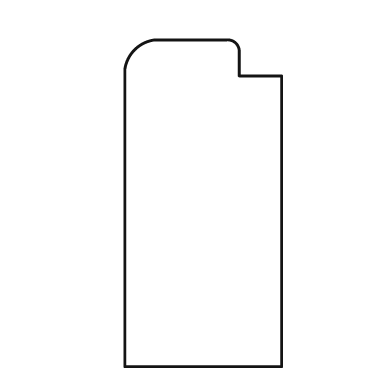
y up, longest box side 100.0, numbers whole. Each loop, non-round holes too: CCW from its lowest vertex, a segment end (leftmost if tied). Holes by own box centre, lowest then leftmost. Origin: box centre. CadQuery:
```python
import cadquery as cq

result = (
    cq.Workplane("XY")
    .moveTo(-24.0, -50.0)
    .lineTo(24.0, -50.0)
    .lineTo(24.0, 39.0)
    .lineTo(11.0, 39.0)
    .lineTo(11.0, 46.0)
    .threePointArc((10.0, 49.0), (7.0, 50.0))
    .lineTo(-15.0, 50.0)
    .threePointArc((-21.0, 47.0), (-24.0, 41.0))
    .close()
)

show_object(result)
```